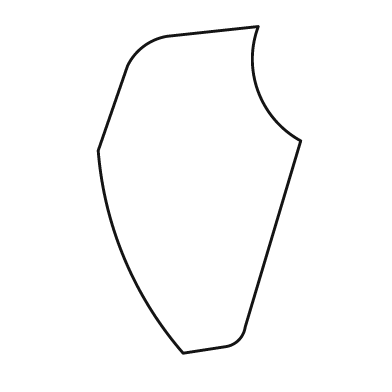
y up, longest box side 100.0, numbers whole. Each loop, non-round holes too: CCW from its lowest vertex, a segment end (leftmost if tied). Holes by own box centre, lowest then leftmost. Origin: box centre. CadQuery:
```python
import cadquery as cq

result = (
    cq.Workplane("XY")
    .moveTo(-5.0, -50.0)
    .lineTo(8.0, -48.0)
    .threePointArc((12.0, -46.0), (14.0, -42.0))
    .lineTo(31.0, 15.0)
    .threePointArc((18.0, 30.0), (18.0, 50.0))
    .lineTo(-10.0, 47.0)
    .threePointArc((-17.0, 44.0), (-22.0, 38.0))
    .lineTo(-31.0, 12.0)
    .threePointArc((-23.0, -21.0), (-5.0, -50.0))
    .close()
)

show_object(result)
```